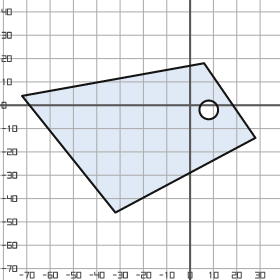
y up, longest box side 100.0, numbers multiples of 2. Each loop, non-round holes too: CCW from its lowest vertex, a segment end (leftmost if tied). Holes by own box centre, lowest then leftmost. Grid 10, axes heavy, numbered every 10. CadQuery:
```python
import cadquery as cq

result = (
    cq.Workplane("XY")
    .moveTo(-32.0, -46.0)
    .lineTo(28.0, -14.0)
    .lineTo(6.0, 18.0)
    .lineTo(-72.0, 4.0)
    .close()
    .moveTo(8.0, -2.0)
    .circle(4.0)
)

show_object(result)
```